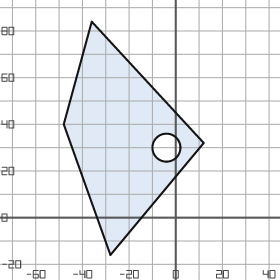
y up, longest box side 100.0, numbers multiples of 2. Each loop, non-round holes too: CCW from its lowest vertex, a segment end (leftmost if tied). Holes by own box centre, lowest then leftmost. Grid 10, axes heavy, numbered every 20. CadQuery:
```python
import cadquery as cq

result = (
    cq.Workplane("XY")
    .moveTo(-28.0, -16.0)
    .lineTo(12.0, 32.0)
    .lineTo(-36.0, 84.0)
    .lineTo(-48.0, 40.0)
    .close()
    .moveTo(-4.0, 30.0)
    .circle(6.0)
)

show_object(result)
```